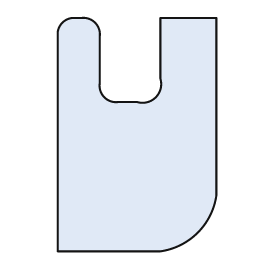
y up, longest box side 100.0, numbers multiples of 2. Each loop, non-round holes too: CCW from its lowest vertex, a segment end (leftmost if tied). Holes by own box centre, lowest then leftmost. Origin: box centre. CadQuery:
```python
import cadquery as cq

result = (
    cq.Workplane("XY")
    .moveTo(-34.0, -50.0)
    .lineTo(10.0, -50.0)
    .threePointArc((26.0, -42.0), (34.0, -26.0))
    .lineTo(34.0, 50.0)
    .lineTo(10.0, 50.0)
    .lineTo(10.0, 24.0)
    .threePointArc((8.0, 16.0), (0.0, 14.0))
    .lineTo(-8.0, 14.0)
    .threePointArc((-14.0, 16.0), (-16.0, 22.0))
    .lineTo(-16.0, 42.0)
    .threePointArc((-18.0, 48.0), (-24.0, 50.0))
    .lineTo(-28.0, 50.0)
    .threePointArc((-32.0, 48.0), (-34.0, 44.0))
    .close()
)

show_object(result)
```